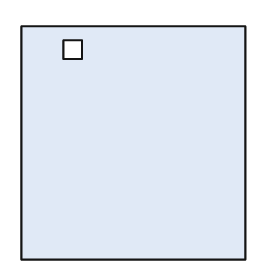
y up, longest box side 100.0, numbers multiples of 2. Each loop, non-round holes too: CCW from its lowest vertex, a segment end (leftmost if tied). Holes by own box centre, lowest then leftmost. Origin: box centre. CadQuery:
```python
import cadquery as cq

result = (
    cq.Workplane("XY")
    .moveTo(-48.0, -50.0)
    .lineTo(48.0, -50.0)
    .lineTo(48.0, 50.0)
    .lineTo(-48.0, 50.0)
    .close()
    .moveTo(-30.0, 36.0)
    .lineTo(-22.0, 36.0)
    .lineTo(-22.0, 44.0)
    .lineTo(-30.0, 44.0)
    .close()
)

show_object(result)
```